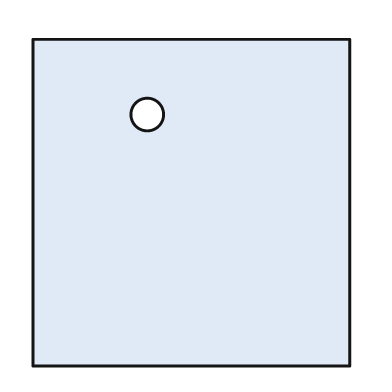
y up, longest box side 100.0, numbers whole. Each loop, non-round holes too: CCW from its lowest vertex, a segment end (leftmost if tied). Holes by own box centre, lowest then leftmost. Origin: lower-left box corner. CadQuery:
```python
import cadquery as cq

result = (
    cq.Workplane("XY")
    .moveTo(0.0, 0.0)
    .lineTo(97.0, 0.0)
    .lineTo(97.0, 100.0)
    .lineTo(0.0, 100.0)
    .close()
    .moveTo(35.0, 77.0)
    .circle(5.0)
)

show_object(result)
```